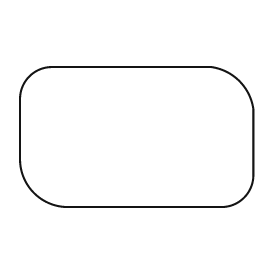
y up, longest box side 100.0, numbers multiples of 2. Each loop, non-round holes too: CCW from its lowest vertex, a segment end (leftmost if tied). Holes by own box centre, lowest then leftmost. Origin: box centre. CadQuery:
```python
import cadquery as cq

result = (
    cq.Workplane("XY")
    .moveTo(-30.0, -30.0)
    .lineTo(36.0, -30.0)
    .threePointArc((46.0, -26.0), (50.0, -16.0))
    .lineTo(50.0, 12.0)
    .threePointArc((44.0, 24.0), (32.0, 30.0))
    .lineTo(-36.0, 30.0)
    .threePointArc((-46.0, 26.0), (-50.0, 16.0))
    .lineTo(-50.0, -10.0)
    .threePointArc((-44.0, -24.0), (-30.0, -30.0))
    .close()
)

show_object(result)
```